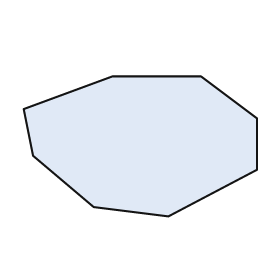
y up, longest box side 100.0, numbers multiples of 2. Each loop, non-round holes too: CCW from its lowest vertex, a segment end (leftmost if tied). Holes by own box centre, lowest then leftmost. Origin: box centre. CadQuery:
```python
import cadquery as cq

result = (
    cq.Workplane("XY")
    .moveTo(12.0, -30.0)
    .lineTo(50.0, -10.0)
    .lineTo(50.0, 12.0)
    .lineTo(26.0, 30.0)
    .lineTo(-12.0, 30.0)
    .lineTo(-50.0, 16.0)
    .lineTo(-46.0, -4.0)
    .lineTo(-20.0, -26.0)
    .close()
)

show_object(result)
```